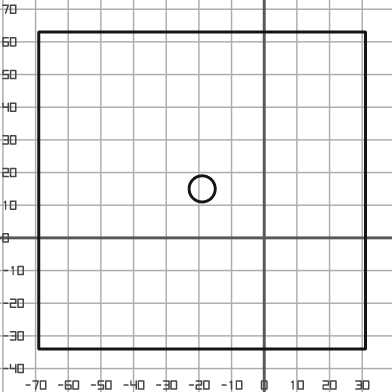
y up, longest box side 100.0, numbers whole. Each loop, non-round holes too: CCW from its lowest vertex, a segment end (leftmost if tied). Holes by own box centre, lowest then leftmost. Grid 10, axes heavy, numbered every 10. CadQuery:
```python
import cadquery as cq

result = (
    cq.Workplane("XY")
    .moveTo(-69.0, -34.0)
    .lineTo(31.0, -34.0)
    .lineTo(31.0, 63.0)
    .lineTo(-69.0, 63.0)
    .close()
    .moveTo(-19.0, 15.0)
    .circle(4.0)
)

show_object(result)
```